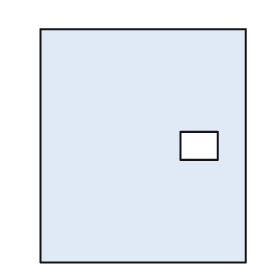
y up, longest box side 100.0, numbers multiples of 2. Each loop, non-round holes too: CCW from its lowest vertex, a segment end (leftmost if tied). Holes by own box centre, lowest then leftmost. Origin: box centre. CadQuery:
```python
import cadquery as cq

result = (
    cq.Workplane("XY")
    .moveTo(-44.0, -50.0)
    .lineTo(44.0, -50.0)
    .lineTo(44.0, 50.0)
    .lineTo(-44.0, 50.0)
    .close()
    .moveTo(16.0, -6.0)
    .lineTo(32.0, -6.0)
    .lineTo(32.0, 6.0)
    .lineTo(16.0, 6.0)
    .close()
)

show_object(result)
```